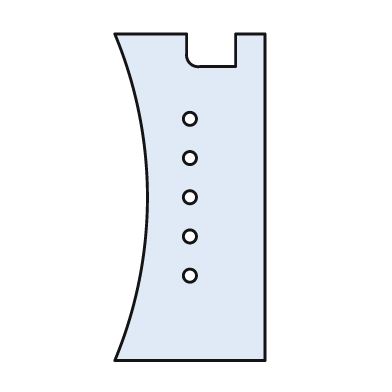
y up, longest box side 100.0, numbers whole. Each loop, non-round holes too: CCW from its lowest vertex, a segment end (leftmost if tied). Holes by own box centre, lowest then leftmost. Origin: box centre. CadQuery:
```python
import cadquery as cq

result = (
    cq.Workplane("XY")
    .moveTo(-23.0, -50.0)
    .lineTo(23.0, -50.0)
    .lineTo(23.0, 50.0)
    .lineTo(14.0, 50.0)
    .lineTo(14.0, 40.0)
    .lineTo(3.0, 40.0)
    .threePointArc((0.0, 41.0), (-1.0, 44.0))
    .lineTo(-1.0, 50.0)
    .lineTo(-23.0, 50.0)
    .threePointArc((-13.0, 0.0), (-23.0, -50.0))
    .close()
    .moveTo(0.0, -24.0)
    .circle(2.0)
    .moveTo(0.0, -12.0)
    .circle(2.0)
    .moveTo(0.0, 0.0)
    .circle(2.0)
    .moveTo(0.0, 12.0)
    .circle(2.0)
    .moveTo(0.0, 24.0)
    .circle(2.0)
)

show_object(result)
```